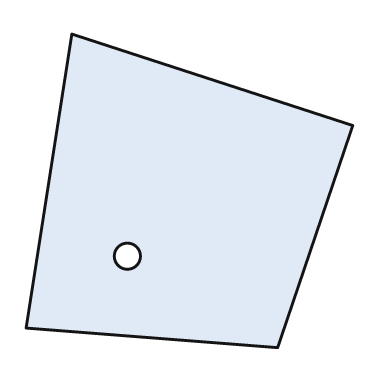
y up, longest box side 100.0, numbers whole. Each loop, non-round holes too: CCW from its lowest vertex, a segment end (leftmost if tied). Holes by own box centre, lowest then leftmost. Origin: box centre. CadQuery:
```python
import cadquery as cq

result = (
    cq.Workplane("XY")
    .moveTo(27.0, -48.0)
    .lineTo(50.0, 20.0)
    .lineTo(-36.0, 48.0)
    .lineTo(-50.0, -42.0)
    .close()
    .moveTo(-19.0, -20.0)
    .circle(4.0)
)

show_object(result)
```